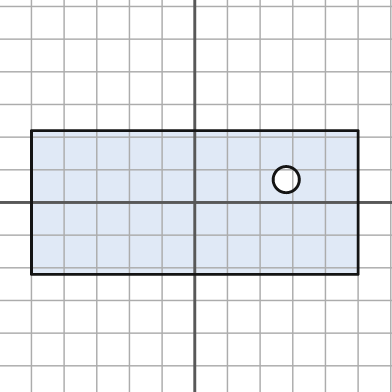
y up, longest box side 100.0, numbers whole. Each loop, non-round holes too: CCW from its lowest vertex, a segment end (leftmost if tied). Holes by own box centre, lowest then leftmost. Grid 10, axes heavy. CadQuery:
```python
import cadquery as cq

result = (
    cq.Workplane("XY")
    .moveTo(-50.0, -22.0)
    .lineTo(50.0, -22.0)
    .lineTo(50.0, 22.0)
    .lineTo(-50.0, 22.0)
    .close()
    .moveTo(28.0, 7.0)
    .circle(4.0)
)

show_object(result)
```